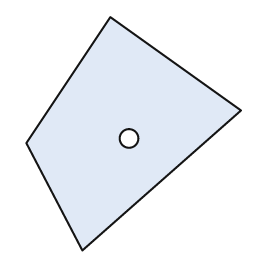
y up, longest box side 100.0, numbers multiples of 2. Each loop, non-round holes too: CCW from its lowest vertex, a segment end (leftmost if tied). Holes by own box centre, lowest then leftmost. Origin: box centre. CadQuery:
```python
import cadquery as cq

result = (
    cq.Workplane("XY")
    .moveTo(-22.0, -50.0)
    .lineTo(46.0, 10.0)
    .lineTo(-10.0, 50.0)
    .lineTo(-46.0, -4.0)
    .close()
    .moveTo(-2.0, -2.0)
    .circle(4.0)
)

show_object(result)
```